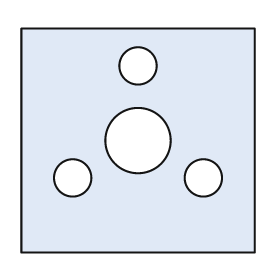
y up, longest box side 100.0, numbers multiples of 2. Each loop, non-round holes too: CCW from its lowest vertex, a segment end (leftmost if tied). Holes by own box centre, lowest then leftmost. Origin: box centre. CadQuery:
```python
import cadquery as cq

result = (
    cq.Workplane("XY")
    .moveTo(-50.0, -48.0)
    .lineTo(50.0, -48.0)
    .lineTo(50.0, 48.0)
    .lineTo(-50.0, 48.0)
    .close()
    .moveTo(-28.0, -16.0)
    .circle(8.0)
    .moveTo(28.0, -16.0)
    .circle(8.0)
    .moveTo(0.0, 0.0)
    .circle(14.0)
    .moveTo(0.0, 32.0)
    .circle(8.0)
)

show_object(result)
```